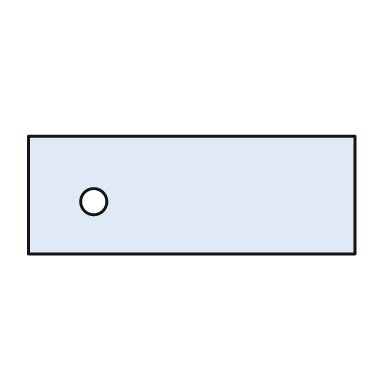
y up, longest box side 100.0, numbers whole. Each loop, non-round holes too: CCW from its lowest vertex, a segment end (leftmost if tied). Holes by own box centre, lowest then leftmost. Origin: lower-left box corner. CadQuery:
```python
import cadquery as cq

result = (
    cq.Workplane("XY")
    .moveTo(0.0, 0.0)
    .lineTo(100.0, 0.0)
    .lineTo(100.0, 36.0)
    .lineTo(0.0, 36.0)
    .close()
    .moveTo(20.0, 16.0)
    .circle(4.0)
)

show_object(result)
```